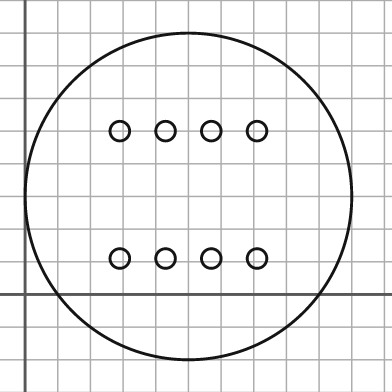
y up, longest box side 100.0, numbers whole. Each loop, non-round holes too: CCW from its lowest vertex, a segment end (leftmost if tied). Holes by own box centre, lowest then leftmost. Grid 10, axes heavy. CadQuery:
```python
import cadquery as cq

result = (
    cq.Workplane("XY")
    .moveTo(50.0, 30.0)
    .circle(50.0)
    .moveTo(29.0, 11.0)
    .circle(3.0)
    .moveTo(43.0, 11.0)
    .circle(3.0)
    .moveTo(57.0, 11.0)
    .circle(3.0)
    .moveTo(71.0, 11.0)
    .circle(3.0)
    .moveTo(29.0, 50.0)
    .circle(3.0)
    .moveTo(43.0, 50.0)
    .circle(3.0)
    .moveTo(57.0, 50.0)
    .circle(3.0)
    .moveTo(71.0, 50.0)
    .circle(3.0)
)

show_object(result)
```